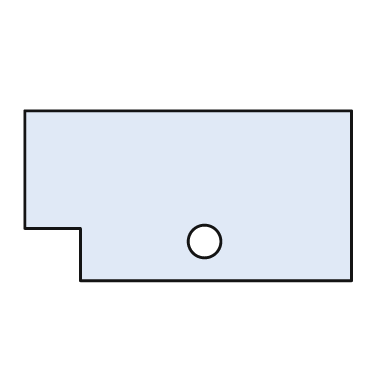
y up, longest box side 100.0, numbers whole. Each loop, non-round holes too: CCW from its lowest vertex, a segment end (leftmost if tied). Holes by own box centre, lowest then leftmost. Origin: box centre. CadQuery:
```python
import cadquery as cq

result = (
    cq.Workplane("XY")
    .moveTo(-33.0, -26.0)
    .lineTo(50.0, -26.0)
    .lineTo(50.0, 26.0)
    .lineTo(-50.0, 26.0)
    .lineTo(-50.0, -10.0)
    .lineTo(-33.0, -10.0)
    .close()
    .moveTo(5.0, -14.0)
    .circle(5.0)
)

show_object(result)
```